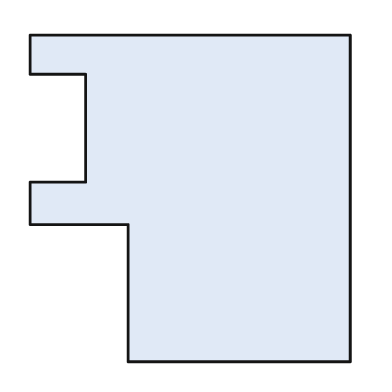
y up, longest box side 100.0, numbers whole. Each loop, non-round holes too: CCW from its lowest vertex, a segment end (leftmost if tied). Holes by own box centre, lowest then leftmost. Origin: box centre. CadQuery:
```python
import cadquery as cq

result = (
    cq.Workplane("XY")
    .moveTo(-19.0, -50.0)
    .lineTo(49.0, -50.0)
    .lineTo(49.0, 50.0)
    .lineTo(-49.0, 50.0)
    .lineTo(-49.0, 38.0)
    .lineTo(-32.0, 38.0)
    .lineTo(-32.0, 5.0)
    .lineTo(-49.0, 5.0)
    .lineTo(-49.0, -8.0)
    .lineTo(-19.0, -8.0)
    .close()
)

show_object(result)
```